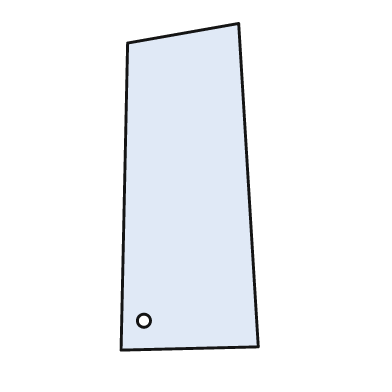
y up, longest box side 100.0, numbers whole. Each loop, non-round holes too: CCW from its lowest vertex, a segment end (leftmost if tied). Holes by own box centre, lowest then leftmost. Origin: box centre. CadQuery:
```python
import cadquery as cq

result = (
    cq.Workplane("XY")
    .moveTo(-21.0, -50.0)
    .lineTo(21.0, -49.0)
    .lineTo(15.0, 50.0)
    .lineTo(-19.0, 44.0)
    .close()
    .moveTo(-14.0, -41.0)
    .circle(2.0)
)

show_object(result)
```